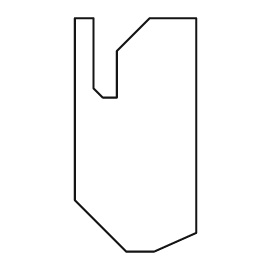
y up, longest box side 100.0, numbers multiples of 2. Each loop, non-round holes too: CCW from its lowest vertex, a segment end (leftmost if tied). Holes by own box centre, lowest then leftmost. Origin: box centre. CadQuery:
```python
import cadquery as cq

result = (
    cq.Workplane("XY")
    .moveTo(-4.0, -50.0)
    .lineTo(8.0, -50.0)
    .lineTo(26.0, -42.0)
    .lineTo(26.0, 50.0)
    .lineTo(6.0, 50.0)
    .lineTo(-8.0, 36.0)
    .lineTo(-8.0, 16.0)
    .lineTo(-14.0, 16.0)
    .lineTo(-18.0, 20.0)
    .lineTo(-18.0, 50.0)
    .lineTo(-26.0, 50.0)
    .lineTo(-26.0, -28.0)
    .close()
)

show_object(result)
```